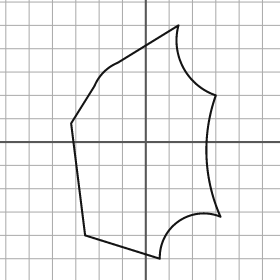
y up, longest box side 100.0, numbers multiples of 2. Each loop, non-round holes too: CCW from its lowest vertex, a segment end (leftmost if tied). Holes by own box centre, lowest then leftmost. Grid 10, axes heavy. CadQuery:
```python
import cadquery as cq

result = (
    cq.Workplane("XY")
    .moveTo(6.0, -50.0)
    .threePointArc((14.0, -34.0), (32.0, -32.0))
    .threePointArc((26.0, -6.0), (30.0, 20.0))
    .threePointArc((16.0, 32.0), (14.0, 50.0))
    .lineTo(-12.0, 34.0)
    .threePointArc((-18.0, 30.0), (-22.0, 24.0))
    .lineTo(-32.0, 8.0)
    .lineTo(-26.0, -40.0)
    .close()
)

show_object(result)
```